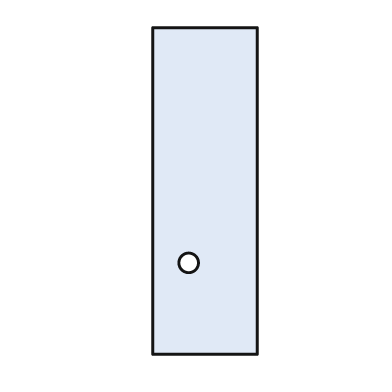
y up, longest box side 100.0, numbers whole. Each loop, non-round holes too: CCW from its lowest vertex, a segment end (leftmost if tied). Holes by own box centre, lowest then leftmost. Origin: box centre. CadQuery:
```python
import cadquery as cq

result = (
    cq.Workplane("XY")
    .moveTo(-16.0, -50.0)
    .lineTo(16.0, -50.0)
    .lineTo(16.0, 50.0)
    .lineTo(-16.0, 50.0)
    .close()
    .moveTo(-5.0, -22.0)
    .circle(3.0)
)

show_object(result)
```